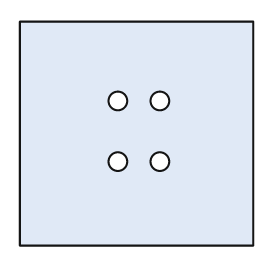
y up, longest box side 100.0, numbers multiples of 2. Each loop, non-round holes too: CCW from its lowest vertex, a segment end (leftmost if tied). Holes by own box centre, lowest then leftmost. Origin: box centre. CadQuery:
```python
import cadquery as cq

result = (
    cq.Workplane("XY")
    .moveTo(-50.0, -48.0)
    .lineTo(50.0, -48.0)
    .lineTo(50.0, 48.0)
    .lineTo(-50.0, 48.0)
    .close()
    .moveTo(-8.0, -12.0)
    .circle(4.0)
    .moveTo(10.0, -12.0)
    .circle(4.0)
    .moveTo(-8.0, 14.0)
    .circle(4.0)
    .moveTo(10.0, 14.0)
    .circle(4.0)
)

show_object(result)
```